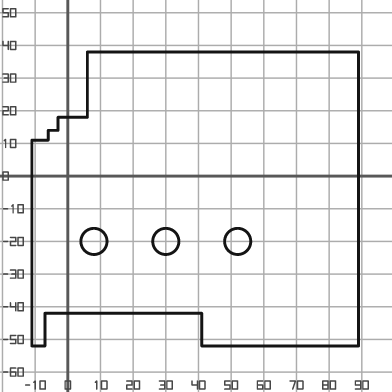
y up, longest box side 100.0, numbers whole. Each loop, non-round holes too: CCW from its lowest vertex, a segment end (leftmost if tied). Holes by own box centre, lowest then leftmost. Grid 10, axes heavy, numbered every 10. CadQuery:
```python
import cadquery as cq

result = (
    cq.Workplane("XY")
    .moveTo(-11.0, -52.0)
    .lineTo(-7.0, -52.0)
    .lineTo(-7.0, -42.0)
    .lineTo(41.0, -42.0)
    .lineTo(41.0, -52.0)
    .lineTo(89.0, -52.0)
    .lineTo(89.0, 38.0)
    .lineTo(6.0, 38.0)
    .lineTo(6.0, 18.0)
    .lineTo(-3.0, 18.0)
    .lineTo(-3.0, 14.0)
    .lineTo(-6.0, 14.0)
    .lineTo(-6.0, 11.0)
    .lineTo(-11.0, 11.0)
    .close()
    .moveTo(8.0, -20.0)
    .circle(4.0)
    .moveTo(30.0, -20.0)
    .circle(4.0)
    .moveTo(52.0, -20.0)
    .circle(4.0)
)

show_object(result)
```